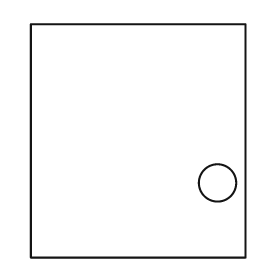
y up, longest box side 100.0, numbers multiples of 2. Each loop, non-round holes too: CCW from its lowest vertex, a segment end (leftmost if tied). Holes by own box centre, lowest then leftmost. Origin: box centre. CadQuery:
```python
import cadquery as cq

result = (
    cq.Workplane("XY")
    .moveTo(-46.0, -50.0)
    .lineTo(46.0, -50.0)
    .lineTo(46.0, 50.0)
    .lineTo(-46.0, 50.0)
    .close()
    .moveTo(34.0, -18.0)
    .circle(8.0)
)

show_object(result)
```